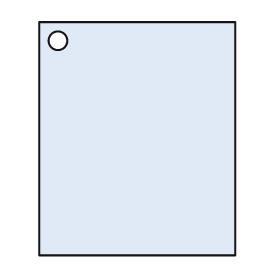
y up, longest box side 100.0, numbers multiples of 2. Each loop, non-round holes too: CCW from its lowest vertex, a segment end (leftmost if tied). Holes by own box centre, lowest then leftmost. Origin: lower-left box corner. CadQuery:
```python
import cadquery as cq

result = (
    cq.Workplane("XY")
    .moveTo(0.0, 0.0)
    .lineTo(84.0, 0.0)
    .lineTo(84.0, 100.0)
    .lineTo(0.0, 100.0)
    .close()
    .moveTo(8.0, 92.0)
    .circle(4.0)
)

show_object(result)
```